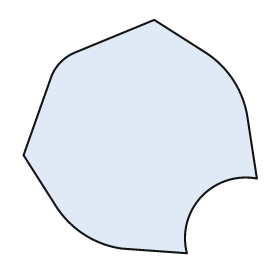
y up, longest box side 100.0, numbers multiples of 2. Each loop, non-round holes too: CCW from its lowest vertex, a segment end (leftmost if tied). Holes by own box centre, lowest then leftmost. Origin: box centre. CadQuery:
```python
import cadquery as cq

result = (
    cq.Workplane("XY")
    .moveTo(20.0, -50.0)
    .threePointArc((26.0, -26.0), (50.0, -18.0))
    .lineTo(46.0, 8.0)
    .threePointArc((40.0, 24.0), (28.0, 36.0))
    .lineTo(6.0, 50.0)
    .lineTo(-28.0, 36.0)
    .threePointArc((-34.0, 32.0), (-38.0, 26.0))
    .lineTo(-50.0, -8.0)
    .lineTo(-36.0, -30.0)
    .threePointArc((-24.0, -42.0), (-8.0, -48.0))
    .close()
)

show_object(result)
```